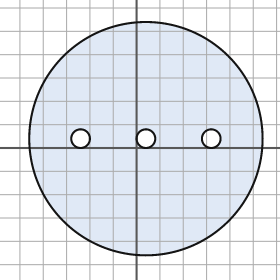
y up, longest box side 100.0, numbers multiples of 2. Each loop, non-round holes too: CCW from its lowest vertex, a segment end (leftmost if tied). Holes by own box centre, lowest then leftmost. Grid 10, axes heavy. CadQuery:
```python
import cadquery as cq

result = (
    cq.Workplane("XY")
    .moveTo(4.0, 4.0)
    .circle(50.0)
    .moveTo(-24.0, 4.0)
    .circle(4.0)
    .moveTo(4.0, 4.0)
    .circle(4.0)
    .moveTo(32.0, 4.0)
    .circle(4.0)
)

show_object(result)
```